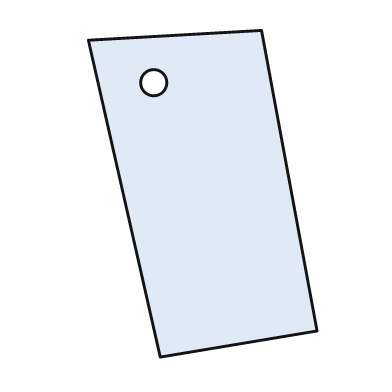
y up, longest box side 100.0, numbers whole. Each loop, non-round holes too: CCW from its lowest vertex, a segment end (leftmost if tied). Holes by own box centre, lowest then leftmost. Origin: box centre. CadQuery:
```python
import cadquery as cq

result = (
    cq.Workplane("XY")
    .moveTo(-13.0, -50.0)
    .lineTo(35.0, -42.0)
    .lineTo(18.0, 50.0)
    .lineTo(-35.0, 47.0)
    .close()
    .moveTo(-15.0, 34.0)
    .circle(4.0)
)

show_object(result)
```